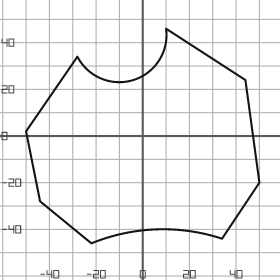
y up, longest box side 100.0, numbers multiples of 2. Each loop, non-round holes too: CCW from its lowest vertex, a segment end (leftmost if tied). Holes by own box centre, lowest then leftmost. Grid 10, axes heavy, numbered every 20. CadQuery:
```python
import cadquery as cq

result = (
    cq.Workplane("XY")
    .moveTo(-22.0, -46.0)
    .threePointArc((6.0, -40.0), (34.0, -44.0))
    .lineTo(50.0, -20.0)
    .lineTo(44.0, 24.0)
    .lineTo(10.0, 46.0)
    .threePointArc((-4.0, 24.0), (-28.0, 34.0))
    .lineTo(-50.0, 2.0)
    .lineTo(-44.0, -28.0)
    .close()
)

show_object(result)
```